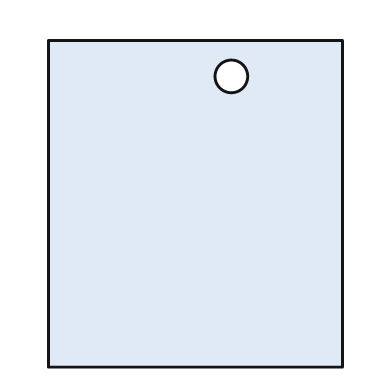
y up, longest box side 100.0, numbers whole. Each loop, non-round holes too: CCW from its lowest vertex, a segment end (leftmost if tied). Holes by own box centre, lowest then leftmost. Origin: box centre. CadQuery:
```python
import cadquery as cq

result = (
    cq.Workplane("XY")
    .moveTo(-45.0, -50.0)
    .lineTo(45.0, -50.0)
    .lineTo(45.0, 50.0)
    .lineTo(-45.0, 50.0)
    .close()
    .moveTo(11.0, 39.0)
    .circle(5.0)
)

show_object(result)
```